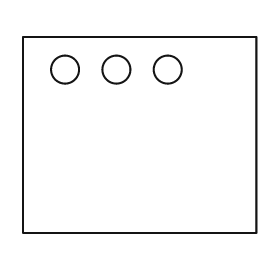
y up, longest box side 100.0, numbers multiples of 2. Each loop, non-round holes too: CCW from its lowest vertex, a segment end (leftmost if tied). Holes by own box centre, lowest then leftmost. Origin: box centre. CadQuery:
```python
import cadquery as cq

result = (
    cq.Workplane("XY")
    .moveTo(-50.0, -42.0)
    .lineTo(50.0, -42.0)
    .lineTo(50.0, 42.0)
    .lineTo(-50.0, 42.0)
    .close()
    .moveTo(-32.0, 28.0)
    .circle(6.0)
    .moveTo(-10.0, 28.0)
    .circle(6.0)
    .moveTo(12.0, 28.0)
    .circle(6.0)
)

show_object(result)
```